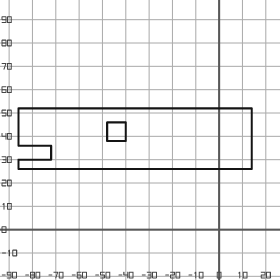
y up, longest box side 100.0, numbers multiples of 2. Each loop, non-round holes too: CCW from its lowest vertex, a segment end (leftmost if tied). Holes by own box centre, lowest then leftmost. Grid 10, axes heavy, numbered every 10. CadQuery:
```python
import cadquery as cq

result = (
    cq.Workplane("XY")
    .moveTo(-86.0, 26.0)
    .lineTo(14.0, 26.0)
    .lineTo(14.0, 52.0)
    .lineTo(-86.0, 52.0)
    .lineTo(-86.0, 36.0)
    .lineTo(-72.0, 36.0)
    .lineTo(-72.0, 30.0)
    .lineTo(-86.0, 30.0)
    .close()
    .moveTo(-48.0, 38.0)
    .lineTo(-40.0, 38.0)
    .lineTo(-40.0, 46.0)
    .lineTo(-48.0, 46.0)
    .close()
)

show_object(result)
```